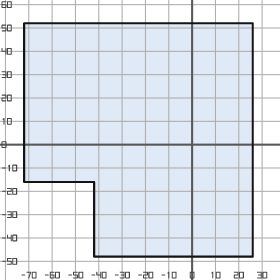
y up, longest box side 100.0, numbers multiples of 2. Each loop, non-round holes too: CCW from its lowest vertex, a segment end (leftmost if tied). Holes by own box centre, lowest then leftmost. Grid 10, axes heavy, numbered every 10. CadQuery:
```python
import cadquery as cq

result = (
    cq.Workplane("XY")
    .moveTo(-42.0, -48.0)
    .lineTo(26.0, -48.0)
    .lineTo(26.0, 52.0)
    .lineTo(-72.0, 52.0)
    .lineTo(-72.0, -16.0)
    .lineTo(-42.0, -16.0)
    .close()
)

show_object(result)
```